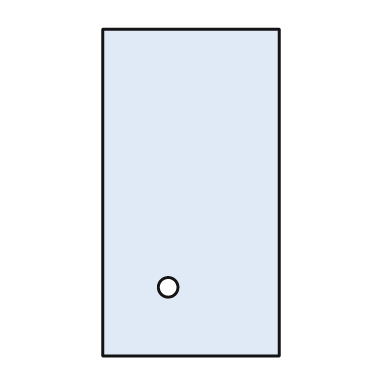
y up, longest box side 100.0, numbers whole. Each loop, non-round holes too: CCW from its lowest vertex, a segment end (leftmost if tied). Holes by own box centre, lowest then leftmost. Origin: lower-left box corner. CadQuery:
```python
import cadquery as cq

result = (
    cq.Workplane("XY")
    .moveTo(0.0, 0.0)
    .lineTo(54.0, 0.0)
    .lineTo(54.0, 100.0)
    .lineTo(0.0, 100.0)
    .close()
    .moveTo(20.0, 21.0)
    .circle(3.0)
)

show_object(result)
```